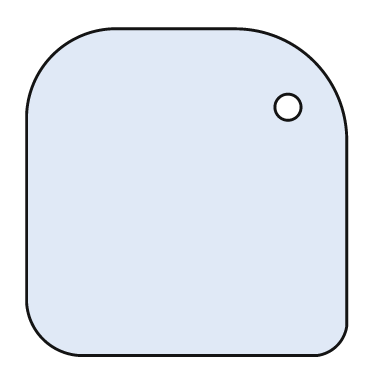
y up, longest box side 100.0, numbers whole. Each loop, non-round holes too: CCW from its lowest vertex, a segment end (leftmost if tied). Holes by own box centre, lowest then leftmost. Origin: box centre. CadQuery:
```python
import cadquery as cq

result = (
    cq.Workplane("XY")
    .moveTo(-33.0, -50.0)
    .lineTo(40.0, -50.0)
    .threePointArc((46.0, -47.0), (49.0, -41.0))
    .lineTo(49.0, 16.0)
    .threePointArc((39.0, 40.0), (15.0, 50.0))
    .lineTo(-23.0, 50.0)
    .threePointArc((-41.0, 42.0), (-49.0, 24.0))
    .lineTo(-49.0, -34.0)
    .threePointArc((-44.0, -45.0), (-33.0, -50.0))
    .close()
    .moveTo(31.0, 26.0)
    .circle(4.0)
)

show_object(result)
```